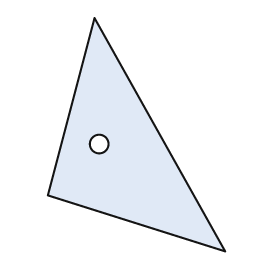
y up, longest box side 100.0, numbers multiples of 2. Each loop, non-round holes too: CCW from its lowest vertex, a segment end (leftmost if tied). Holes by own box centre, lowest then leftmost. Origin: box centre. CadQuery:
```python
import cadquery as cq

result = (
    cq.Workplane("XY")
    .moveTo(38.0, -50.0)
    .lineTo(-18.0, 50.0)
    .lineTo(-38.0, -26.0)
    .close()
    .moveTo(-16.0, -4.0)
    .circle(4.0)
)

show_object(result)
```